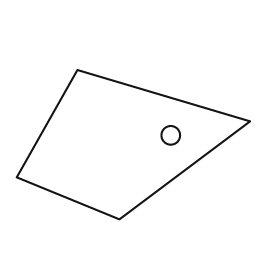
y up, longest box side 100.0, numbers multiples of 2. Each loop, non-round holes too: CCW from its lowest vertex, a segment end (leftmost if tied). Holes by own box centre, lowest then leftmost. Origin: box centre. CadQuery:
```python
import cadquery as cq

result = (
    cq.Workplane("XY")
    .moveTo(-6.0, -32.0)
    .lineTo(50.0, 10.0)
    .lineTo(-24.0, 32.0)
    .lineTo(-50.0, -14.0)
    .close()
    .moveTo(16.0, 4.0)
    .circle(4.0)
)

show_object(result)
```